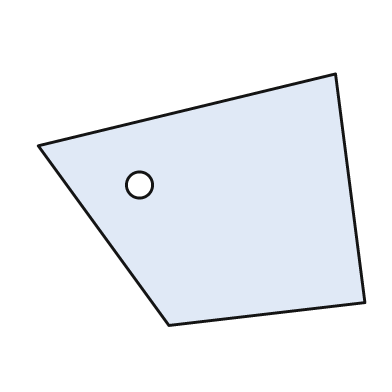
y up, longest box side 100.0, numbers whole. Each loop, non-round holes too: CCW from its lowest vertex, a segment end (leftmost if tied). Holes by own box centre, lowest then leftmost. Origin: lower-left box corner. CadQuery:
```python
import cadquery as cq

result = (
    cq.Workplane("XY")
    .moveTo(40.0, 0.0)
    .lineTo(100.0, 7.0)
    .lineTo(91.0, 77.0)
    .lineTo(0.0, 55.0)
    .close()
    .moveTo(31.0, 43.0)
    .circle(4.0)
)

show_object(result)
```